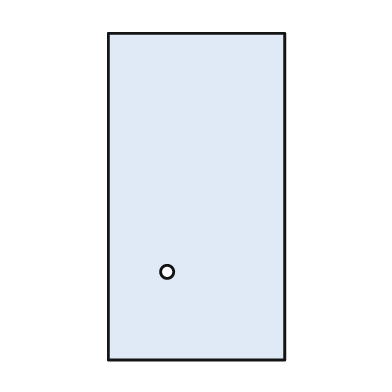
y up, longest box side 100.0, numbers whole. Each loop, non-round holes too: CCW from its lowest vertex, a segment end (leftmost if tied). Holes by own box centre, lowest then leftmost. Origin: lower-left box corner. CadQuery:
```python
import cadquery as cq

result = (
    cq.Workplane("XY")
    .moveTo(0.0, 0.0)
    .lineTo(54.0, 0.0)
    .lineTo(54.0, 100.0)
    .lineTo(0.0, 100.0)
    .close()
    .moveTo(18.0, 27.0)
    .circle(2.0)
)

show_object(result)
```